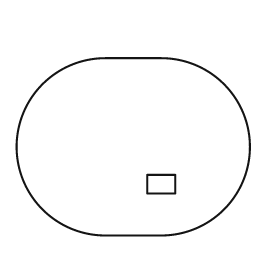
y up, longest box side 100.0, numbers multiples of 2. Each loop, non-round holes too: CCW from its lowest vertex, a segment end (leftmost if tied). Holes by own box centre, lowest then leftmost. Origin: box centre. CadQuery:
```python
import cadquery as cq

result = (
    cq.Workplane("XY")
    .moveTo(-12.0, -38.0)
    .lineTo(12.0, -38.0)
    .threePointArc((50.0, 0.0), (12.0, 38.0))
    .lineTo(-12.0, 38.0)
    .threePointArc((-50.0, 0.0), (-12.0, -38.0))
    .close()
    .moveTo(6.0, -20.0)
    .lineTo(18.0, -20.0)
    .lineTo(18.0, -12.0)
    .lineTo(6.0, -12.0)
    .close()
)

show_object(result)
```